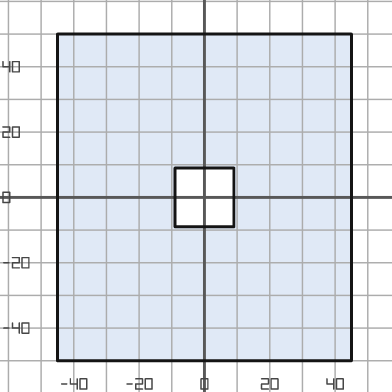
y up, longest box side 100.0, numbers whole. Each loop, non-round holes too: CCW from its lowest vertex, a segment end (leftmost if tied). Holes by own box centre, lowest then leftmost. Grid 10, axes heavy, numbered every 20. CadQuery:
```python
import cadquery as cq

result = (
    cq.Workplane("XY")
    .moveTo(-45.0, -50.0)
    .lineTo(45.0, -50.0)
    .lineTo(45.0, 50.0)
    .lineTo(-45.0, 50.0)
    .close()
    .moveTo(-9.0, -9.0)
    .lineTo(9.0, -9.0)
    .lineTo(9.0, 9.0)
    .lineTo(-9.0, 9.0)
    .close()
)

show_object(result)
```